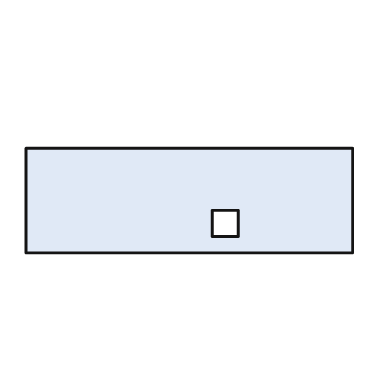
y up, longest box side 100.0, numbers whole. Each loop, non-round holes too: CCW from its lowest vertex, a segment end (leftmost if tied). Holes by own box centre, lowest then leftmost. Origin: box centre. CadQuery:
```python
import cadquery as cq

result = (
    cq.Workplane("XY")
    .moveTo(-50.0, -16.0)
    .lineTo(50.0, -16.0)
    .lineTo(50.0, 16.0)
    .lineTo(-50.0, 16.0)
    .close()
    .moveTo(7.0, -11.0)
    .lineTo(15.0, -11.0)
    .lineTo(15.0, -3.0)
    .lineTo(7.0, -3.0)
    .close()
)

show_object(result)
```